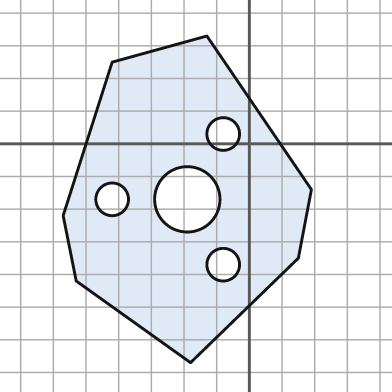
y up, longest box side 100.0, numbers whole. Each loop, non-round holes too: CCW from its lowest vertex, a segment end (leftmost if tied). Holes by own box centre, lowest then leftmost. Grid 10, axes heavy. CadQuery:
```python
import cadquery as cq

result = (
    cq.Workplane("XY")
    .moveTo(-18.0, -67.0)
    .lineTo(15.0, -35.0)
    .lineTo(19.0, -14.0)
    .lineTo(-13.0, 33.0)
    .lineTo(-42.0, 25.0)
    .lineTo(-57.0, -22.0)
    .lineTo(-53.0, -42.0)
    .close()
    .moveTo(-8.0, -37.0)
    .circle(5.0)
    .moveTo(-42.0, -17.0)
    .circle(5.0)
    .moveTo(-19.0, -17.0)
    .circle(10.0)
    .moveTo(-8.0, 3.0)
    .circle(5.0)
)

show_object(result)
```